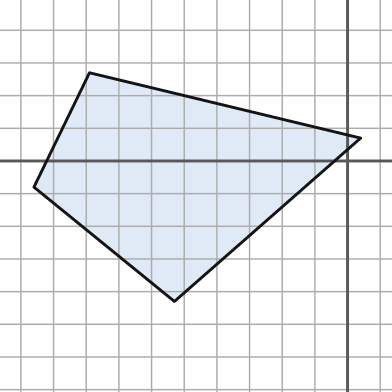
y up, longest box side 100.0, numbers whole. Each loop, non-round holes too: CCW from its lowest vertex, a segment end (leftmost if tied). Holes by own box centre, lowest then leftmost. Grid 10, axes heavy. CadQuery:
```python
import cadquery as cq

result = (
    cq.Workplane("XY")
    .moveTo(-53.0, -43.0)
    .lineTo(4.0, 7.0)
    .lineTo(-79.0, 27.0)
    .lineTo(-96.0, -8.0)
    .close()
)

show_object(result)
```